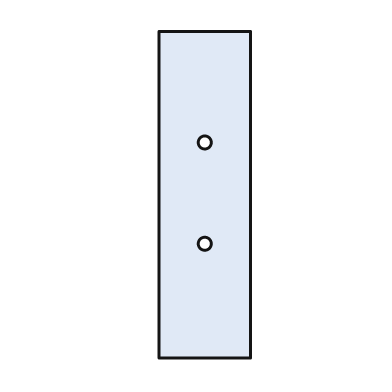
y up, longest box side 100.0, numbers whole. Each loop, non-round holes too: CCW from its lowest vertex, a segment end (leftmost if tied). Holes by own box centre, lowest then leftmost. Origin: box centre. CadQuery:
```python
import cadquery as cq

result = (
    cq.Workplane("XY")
    .moveTo(-14.0, -50.0)
    .lineTo(14.0, -50.0)
    .lineTo(14.0, 50.0)
    .lineTo(-14.0, 50.0)
    .close()
    .moveTo(0.0, -15.0)
    .circle(2.0)
    .moveTo(0.0, 16.0)
    .circle(2.0)
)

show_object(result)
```